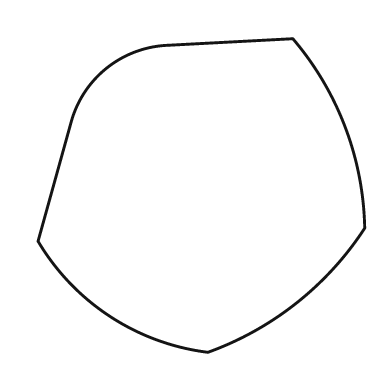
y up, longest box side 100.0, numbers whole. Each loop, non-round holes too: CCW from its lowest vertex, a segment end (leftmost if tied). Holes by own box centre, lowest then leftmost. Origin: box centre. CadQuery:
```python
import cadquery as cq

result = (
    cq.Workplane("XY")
    .moveTo(2.0, -48.0)
    .threePointArc((29.0, -33.0), (50.0, -10.0))
    .threePointArc((44.0, 21.0), (28.0, 48.0))
    .lineTo(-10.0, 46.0)
    .threePointArc((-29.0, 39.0), (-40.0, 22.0))
    .lineTo(-50.0, -14.0)
    .threePointArc((-28.0, -37.0), (2.0, -48.0))
    .close()
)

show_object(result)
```